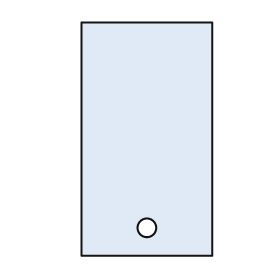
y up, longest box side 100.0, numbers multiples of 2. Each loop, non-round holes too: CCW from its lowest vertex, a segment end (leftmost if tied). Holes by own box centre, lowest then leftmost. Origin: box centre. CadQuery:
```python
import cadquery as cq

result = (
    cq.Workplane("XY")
    .moveTo(-28.0, -50.0)
    .lineTo(28.0, -50.0)
    .lineTo(28.0, 50.0)
    .lineTo(-28.0, 50.0)
    .close()
    .moveTo(0.0, -38.0)
    .circle(4.0)
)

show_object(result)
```